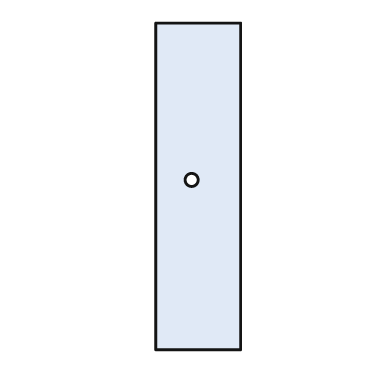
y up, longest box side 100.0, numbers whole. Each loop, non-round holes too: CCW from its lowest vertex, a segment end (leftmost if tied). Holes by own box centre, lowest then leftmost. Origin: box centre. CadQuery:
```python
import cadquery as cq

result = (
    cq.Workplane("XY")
    .moveTo(-13.0, -50.0)
    .lineTo(13.0, -50.0)
    .lineTo(13.0, 50.0)
    .lineTo(-13.0, 50.0)
    .close()
    .moveTo(-2.0, 2.0)
    .circle(2.0)
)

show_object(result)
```